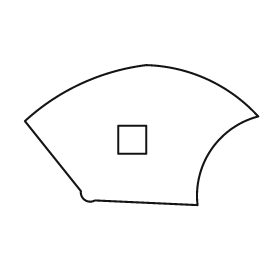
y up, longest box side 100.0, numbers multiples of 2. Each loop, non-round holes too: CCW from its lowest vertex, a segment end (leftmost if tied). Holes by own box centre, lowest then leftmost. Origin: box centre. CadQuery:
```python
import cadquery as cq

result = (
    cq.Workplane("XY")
    .moveTo(24.0, -30.0)
    .threePointArc((30.0, -6.0), (50.0, 8.0))
    .threePointArc((28.0, 24.0), (2.0, 30.0))
    .threePointArc((-26.0, 22.0), (-50.0, 6.0))
    .lineTo(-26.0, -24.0)
    .threePointArc((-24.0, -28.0), (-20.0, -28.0))
    .close()
    .moveTo(-10.0, -8.0)
    .lineTo(2.0, -8.0)
    .lineTo(2.0, 4.0)
    .lineTo(-10.0, 4.0)
    .close()
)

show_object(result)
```